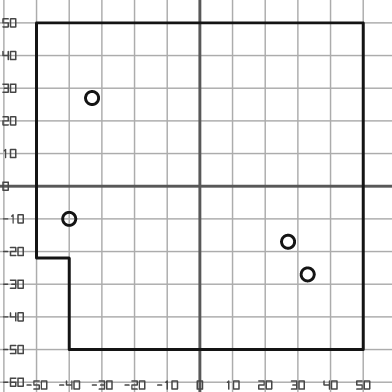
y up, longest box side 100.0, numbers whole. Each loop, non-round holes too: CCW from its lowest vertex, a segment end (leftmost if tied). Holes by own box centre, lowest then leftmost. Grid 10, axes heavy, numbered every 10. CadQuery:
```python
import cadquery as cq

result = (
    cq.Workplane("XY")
    .moveTo(-40.0, -50.0)
    .lineTo(50.0, -50.0)
    .lineTo(50.0, 50.0)
    .lineTo(-50.0, 50.0)
    .lineTo(-50.0, -22.0)
    .lineTo(-40.0, -22.0)
    .close()
    .moveTo(33.0, -27.0)
    .circle(2.0)
    .moveTo(27.0, -17.0)
    .circle(2.0)
    .moveTo(-40.0, -10.0)
    .circle(2.0)
    .moveTo(-33.0, 27.0)
    .circle(2.0)
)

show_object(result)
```